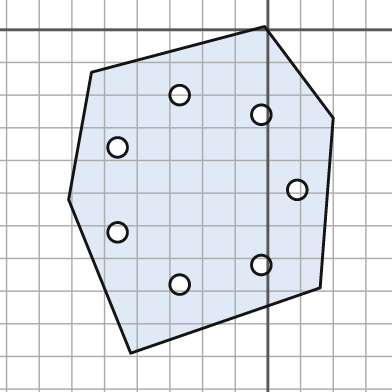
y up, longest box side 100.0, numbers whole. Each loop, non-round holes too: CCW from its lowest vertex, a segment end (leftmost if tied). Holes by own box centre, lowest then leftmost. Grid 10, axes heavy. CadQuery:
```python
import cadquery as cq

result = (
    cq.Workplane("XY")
    .moveTo(-42.0, -99.0)
    .lineTo(16.0, -79.0)
    .lineTo(20.0, -27.0)
    .lineTo(-1.0, 1.0)
    .lineTo(-54.0, -13.0)
    .lineTo(-61.0, -52.0)
    .close()
    .moveTo(-27.0, -78.0)
    .circle(3.0)
    .moveTo(-2.0, -72.0)
    .circle(3.0)
    .moveTo(-46.0, -62.0)
    .circle(3.0)
    .moveTo(9.0, -49.0)
    .circle(3.0)
    .moveTo(-46.0, -36.0)
    .circle(3.0)
    .moveTo(-2.0, -26.0)
    .circle(3.0)
    .moveTo(-27.0, -20.0)
    .circle(3.0)
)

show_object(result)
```